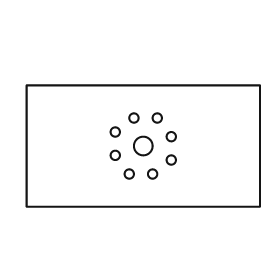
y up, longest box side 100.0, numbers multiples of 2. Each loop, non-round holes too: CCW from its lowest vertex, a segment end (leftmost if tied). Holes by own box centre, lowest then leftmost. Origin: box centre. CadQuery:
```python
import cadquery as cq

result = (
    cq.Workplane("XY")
    .moveTo(-50.0, -26.0)
    .lineTo(50.0, -26.0)
    .lineTo(50.0, 26.0)
    .lineTo(-50.0, 26.0)
    .close()
    .moveTo(-6.0, -12.0)
    .circle(2.0)
    .moveTo(4.0, -12.0)
    .circle(2.0)
    .moveTo(12.0, -6.0)
    .circle(2.0)
    .moveTo(-12.0, -4.0)
    .circle(2.0)
    .moveTo(0.0, 0.0)
    .circle(4.0)
    .moveTo(12.0, 4.0)
    .circle(2.0)
    .moveTo(-12.0, 6.0)
    .circle(2.0)
    .moveTo(-4.0, 12.0)
    .circle(2.0)
    .moveTo(6.0, 12.0)
    .circle(2.0)
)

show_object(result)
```